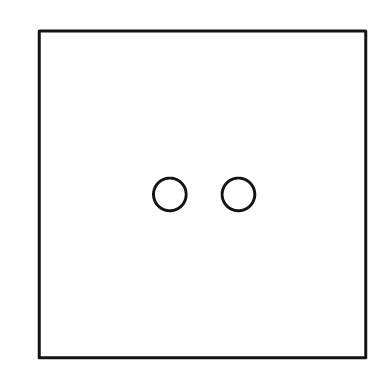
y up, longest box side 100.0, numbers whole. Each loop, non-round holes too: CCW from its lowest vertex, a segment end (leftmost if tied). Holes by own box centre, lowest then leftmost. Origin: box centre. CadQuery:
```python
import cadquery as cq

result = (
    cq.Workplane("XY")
    .moveTo(-50.0, -50.0)
    .lineTo(50.0, -50.0)
    .lineTo(50.0, 50.0)
    .lineTo(-50.0, 50.0)
    .close()
    .moveTo(-10.0, 0.0)
    .circle(5.0)
    .moveTo(11.0, 0.0)
    .circle(5.0)
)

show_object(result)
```